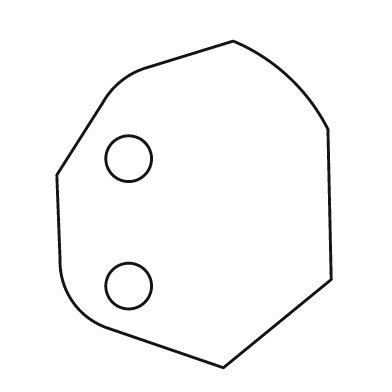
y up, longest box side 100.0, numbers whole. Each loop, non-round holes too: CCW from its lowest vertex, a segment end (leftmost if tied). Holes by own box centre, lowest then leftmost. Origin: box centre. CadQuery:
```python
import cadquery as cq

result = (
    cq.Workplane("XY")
    .moveTo(9.0, -50.0)
    .lineTo(42.0, -23.0)
    .lineTo(41.0, 23.0)
    .threePointArc((29.0, 39.0), (12.0, 50.0))
    .lineTo(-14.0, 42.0)
    .threePointArc((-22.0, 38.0), (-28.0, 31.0))
    .lineTo(-42.0, 9.0)
    .lineTo(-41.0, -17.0)
    .threePointArc((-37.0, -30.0), (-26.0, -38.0))
    .close()
    .moveTo(-20.0, -25.0)
    .circle(7.0)
    .moveTo(-20.0, 14.0)
    .circle(7.0)
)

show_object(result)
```